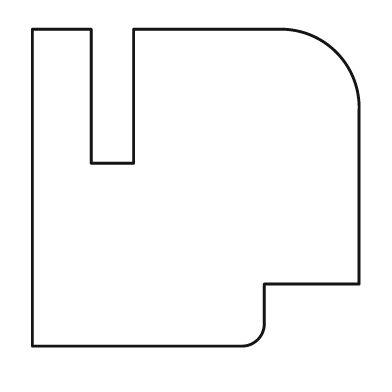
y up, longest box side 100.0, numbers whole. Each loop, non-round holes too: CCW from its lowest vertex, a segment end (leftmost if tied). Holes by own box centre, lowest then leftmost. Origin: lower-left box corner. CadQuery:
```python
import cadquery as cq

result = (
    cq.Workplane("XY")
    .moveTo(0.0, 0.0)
    .lineTo(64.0, 0.0)
    .threePointArc((69.0, 2.0), (71.0, 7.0))
    .lineTo(71.0, 19.0)
    .lineTo(100.0, 19.0)
    .lineTo(100.0, 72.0)
    .threePointArc((93.0, 90.0), (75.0, 97.0))
    .lineTo(31.0, 97.0)
    .lineTo(31.0, 56.0)
    .lineTo(18.0, 56.0)
    .lineTo(18.0, 97.0)
    .lineTo(0.0, 97.0)
    .close()
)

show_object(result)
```